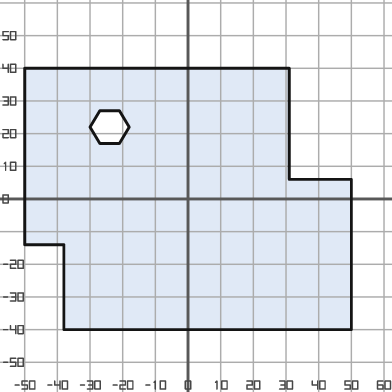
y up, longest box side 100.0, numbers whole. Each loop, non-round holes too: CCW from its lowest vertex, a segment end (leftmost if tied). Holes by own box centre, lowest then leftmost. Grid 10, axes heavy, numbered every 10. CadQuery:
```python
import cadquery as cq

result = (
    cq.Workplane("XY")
    .moveTo(-38.0, -40.0)
    .lineTo(50.0, -40.0)
    .lineTo(50.0, 6.0)
    .lineTo(31.0, 6.0)
    .lineTo(31.0, 40.0)
    .lineTo(-50.0, 40.0)
    .lineTo(-50.0, -14.0)
    .lineTo(-38.0, -14.0)
    .close()
    .moveTo(-27.0, 17.0)
    .lineTo(-21.0, 17.0)
    .lineTo(-18.0, 22.0)
    .lineTo(-21.0, 27.0)
    .lineTo(-27.0, 27.0)
    .lineTo(-30.0, 22.0)
    .close()
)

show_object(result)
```